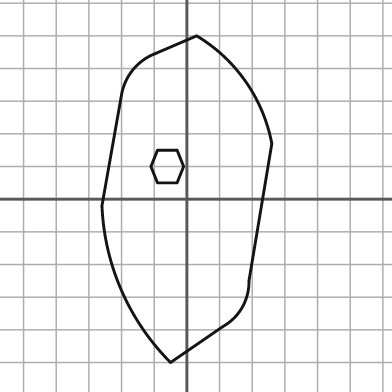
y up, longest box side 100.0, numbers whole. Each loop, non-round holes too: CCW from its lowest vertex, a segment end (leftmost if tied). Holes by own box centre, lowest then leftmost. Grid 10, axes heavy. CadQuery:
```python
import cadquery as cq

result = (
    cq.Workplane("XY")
    .moveTo(-5.0, -50.0)
    .lineTo(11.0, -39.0)
    .threePointArc((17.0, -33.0), (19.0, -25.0))
    .lineTo(26.0, 17.0)
    .threePointArc((18.0, 36.0), (3.0, 50.0))
    .lineTo(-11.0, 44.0)
    .threePointArc((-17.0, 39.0), (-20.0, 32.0))
    .lineTo(-26.0, -2.0)
    .threePointArc((-20.0, -28.0), (-5.0, -50.0))
    .close()
    .moveTo(-9.0, 5.0)
    .lineTo(-3.0, 5.0)
    .lineTo(-1.0, 10.0)
    .lineTo(-3.0, 15.0)
    .lineTo(-9.0, 15.0)
    .lineTo(-11.0, 10.0)
    .close()
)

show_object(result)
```